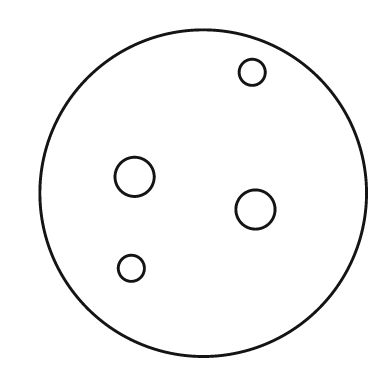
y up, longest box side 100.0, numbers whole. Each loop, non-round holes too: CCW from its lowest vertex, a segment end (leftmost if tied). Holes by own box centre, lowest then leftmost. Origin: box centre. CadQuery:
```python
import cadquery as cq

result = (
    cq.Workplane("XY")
    .moveTo(0.0, 0.0)
    .circle(50.0)
    .moveTo(-22.0, -23.0)
    .circle(4.0)
    .moveTo(16.0, -5.0)
    .circle(6.0)
    .moveTo(-21.0, 5.0)
    .circle(6.0)
    .moveTo(15.0, 37.0)
    .circle(4.0)
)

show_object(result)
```